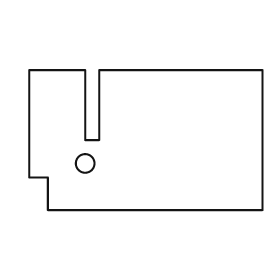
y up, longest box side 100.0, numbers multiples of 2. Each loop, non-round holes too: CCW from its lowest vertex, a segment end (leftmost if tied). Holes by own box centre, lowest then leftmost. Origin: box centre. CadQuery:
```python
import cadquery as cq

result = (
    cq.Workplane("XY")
    .moveTo(-42.0, -30.0)
    .lineTo(50.0, -30.0)
    .lineTo(50.0, 30.0)
    .lineTo(-20.0, 30.0)
    .lineTo(-20.0, 0.0)
    .lineTo(-26.0, 0.0)
    .lineTo(-26.0, 30.0)
    .lineTo(-50.0, 30.0)
    .lineTo(-50.0, -16.0)
    .lineTo(-42.0, -16.0)
    .close()
    .moveTo(-26.0, -10.0)
    .circle(4.0)
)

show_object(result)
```